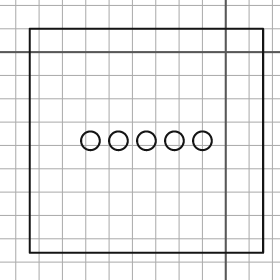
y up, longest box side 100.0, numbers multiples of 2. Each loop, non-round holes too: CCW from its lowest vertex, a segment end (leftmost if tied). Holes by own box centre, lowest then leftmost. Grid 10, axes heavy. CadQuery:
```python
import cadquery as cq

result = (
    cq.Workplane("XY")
    .moveTo(-84.0, -86.0)
    .lineTo(16.0, -86.0)
    .lineTo(16.0, 10.0)
    .lineTo(-84.0, 10.0)
    .close()
    .moveTo(-58.0, -38.0)
    .circle(4.0)
    .moveTo(-46.0, -38.0)
    .circle(4.0)
    .moveTo(-34.0, -38.0)
    .circle(4.0)
    .moveTo(-22.0, -38.0)
    .circle(4.0)
    .moveTo(-10.0, -38.0)
    .circle(4.0)
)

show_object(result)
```